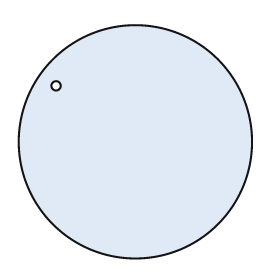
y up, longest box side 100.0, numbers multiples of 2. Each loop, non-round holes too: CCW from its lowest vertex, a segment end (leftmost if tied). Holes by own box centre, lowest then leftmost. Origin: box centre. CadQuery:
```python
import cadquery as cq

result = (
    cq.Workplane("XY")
    .moveTo(0.0, 0.0)
    .circle(50.0)
    .moveTo(-34.0, 24.0)
    .circle(2.0)
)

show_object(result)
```